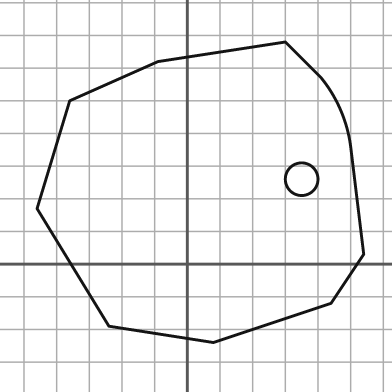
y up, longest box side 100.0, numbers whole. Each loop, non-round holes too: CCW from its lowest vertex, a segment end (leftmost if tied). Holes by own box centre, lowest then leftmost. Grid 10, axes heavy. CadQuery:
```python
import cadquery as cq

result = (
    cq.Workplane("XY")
    .moveTo(8.0, -24.0)
    .lineTo(44.0, -12.0)
    .lineTo(54.0, 3.0)
    .lineTo(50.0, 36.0)
    .threePointArc((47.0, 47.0), (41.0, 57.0))
    .lineTo(30.0, 68.0)
    .lineTo(-9.0, 62.0)
    .lineTo(-36.0, 50.0)
    .lineTo(-46.0, 17.0)
    .lineTo(-24.0, -19.0)
    .close()
    .moveTo(35.0, 26.0)
    .circle(5.0)
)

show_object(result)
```